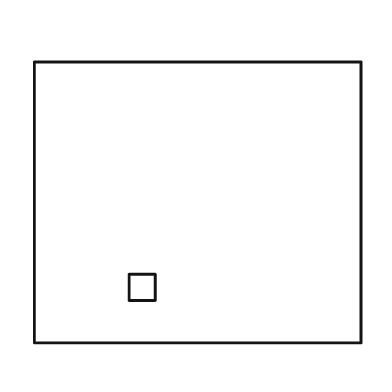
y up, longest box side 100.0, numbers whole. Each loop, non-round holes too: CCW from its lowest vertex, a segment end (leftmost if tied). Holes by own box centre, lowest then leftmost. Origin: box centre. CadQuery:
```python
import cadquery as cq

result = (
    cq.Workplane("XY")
    .moveTo(-50.0, -43.0)
    .lineTo(50.0, -43.0)
    .lineTo(50.0, 43.0)
    .lineTo(-50.0, 43.0)
    .close()
    .moveTo(-21.0, -30.0)
    .lineTo(-13.0, -30.0)
    .lineTo(-13.0, -22.0)
    .lineTo(-21.0, -22.0)
    .close()
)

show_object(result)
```